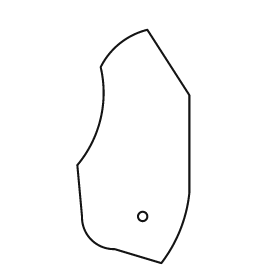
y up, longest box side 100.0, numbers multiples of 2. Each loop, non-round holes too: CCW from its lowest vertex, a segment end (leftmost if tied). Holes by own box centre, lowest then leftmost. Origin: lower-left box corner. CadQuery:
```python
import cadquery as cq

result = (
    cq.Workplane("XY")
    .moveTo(36.0, 0.0)
    .threePointArc((44.0, 14.0), (48.0, 30.0))
    .lineTo(48.0, 72.0)
    .lineTo(30.0, 100.0)
    .threePointArc((18.0, 94.0), (10.0, 84.0))
    .threePointArc((10.0, 62.0), (0.0, 42.0))
    .lineTo(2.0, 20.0)
    .threePointArc((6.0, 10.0), (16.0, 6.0))
    .close()
    .moveTo(28.0, 20.0)
    .circle(2.0)
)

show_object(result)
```